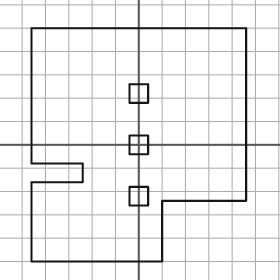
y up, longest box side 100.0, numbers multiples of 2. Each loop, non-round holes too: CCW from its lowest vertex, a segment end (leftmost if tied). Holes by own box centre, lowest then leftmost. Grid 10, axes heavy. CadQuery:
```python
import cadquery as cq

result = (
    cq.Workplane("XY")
    .moveTo(-46.0, -50.0)
    .lineTo(10.0, -50.0)
    .lineTo(10.0, -24.0)
    .lineTo(46.0, -24.0)
    .lineTo(46.0, 50.0)
    .lineTo(-46.0, 50.0)
    .lineTo(-46.0, -8.0)
    .lineTo(-24.0, -8.0)
    .lineTo(-24.0, -16.0)
    .lineTo(-46.0, -16.0)
    .close()
    .moveTo(-4.0, -26.0)
    .lineTo(4.0, -26.0)
    .lineTo(4.0, -18.0)
    .lineTo(-4.0, -18.0)
    .close()
    .moveTo(-4.0, -4.0)
    .lineTo(4.0, -4.0)
    .lineTo(4.0, 4.0)
    .lineTo(-4.0, 4.0)
    .close()
    .moveTo(-4.0, 18.0)
    .lineTo(4.0, 18.0)
    .lineTo(4.0, 26.0)
    .lineTo(-4.0, 26.0)
    .close()
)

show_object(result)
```